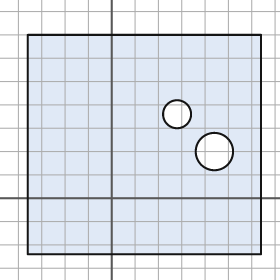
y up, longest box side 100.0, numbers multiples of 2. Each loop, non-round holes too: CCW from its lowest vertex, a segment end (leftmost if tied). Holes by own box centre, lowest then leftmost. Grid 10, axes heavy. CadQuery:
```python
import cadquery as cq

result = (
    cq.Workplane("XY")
    .moveTo(-36.0, -24.0)
    .lineTo(64.0, -24.0)
    .lineTo(64.0, 70.0)
    .lineTo(-36.0, 70.0)
    .close()
    .moveTo(44.0, 20.0)
    .circle(8.0)
    .moveTo(28.0, 36.0)
    .circle(6.0)
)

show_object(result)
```